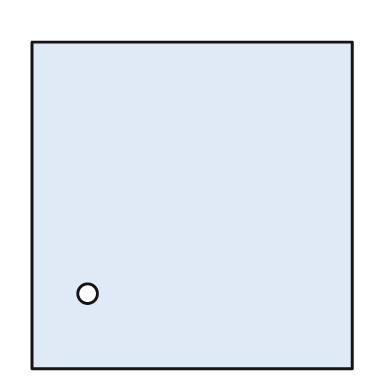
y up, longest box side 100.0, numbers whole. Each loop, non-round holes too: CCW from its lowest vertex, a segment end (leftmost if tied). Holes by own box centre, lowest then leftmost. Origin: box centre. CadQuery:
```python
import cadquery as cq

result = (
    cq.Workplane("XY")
    .moveTo(-49.0, -50.0)
    .lineTo(49.0, -50.0)
    .lineTo(49.0, 50.0)
    .lineTo(-49.0, 50.0)
    .close()
    .moveTo(-32.0, -27.0)
    .circle(3.0)
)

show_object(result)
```